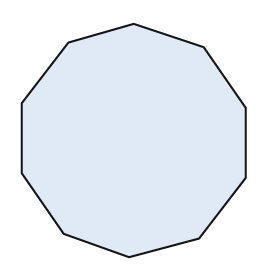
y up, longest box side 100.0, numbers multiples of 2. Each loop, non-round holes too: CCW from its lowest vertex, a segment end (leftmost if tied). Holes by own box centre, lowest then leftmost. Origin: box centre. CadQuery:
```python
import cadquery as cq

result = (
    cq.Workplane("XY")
    .moveTo(-2.0, -50.0)
    .lineTo(28.0, -42.0)
    .lineTo(48.0, -16.0)
    .lineTo(48.0, 14.0)
    .lineTo(30.0, 40.0)
    .lineTo(0.0, 50.0)
    .lineTo(-28.0, 42.0)
    .lineTo(-48.0, 16.0)
    .lineTo(-48.0, -14.0)
    .lineTo(-30.0, -40.0)
    .close()
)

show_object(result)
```